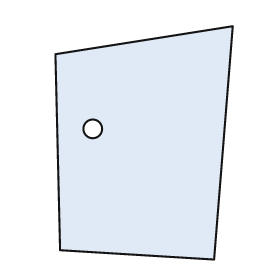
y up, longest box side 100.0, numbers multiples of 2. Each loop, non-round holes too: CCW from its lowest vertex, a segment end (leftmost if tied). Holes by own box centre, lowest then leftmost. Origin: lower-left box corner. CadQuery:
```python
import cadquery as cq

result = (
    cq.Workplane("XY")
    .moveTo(68.0, 0.0)
    .lineTo(76.0, 100.0)
    .lineTo(0.0, 88.0)
    .lineTo(2.0, 4.0)
    .close()
    .moveTo(16.0, 56.0)
    .circle(4.0)
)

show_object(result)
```